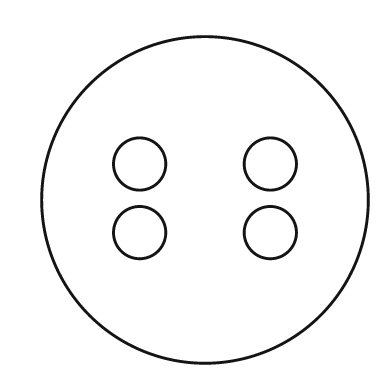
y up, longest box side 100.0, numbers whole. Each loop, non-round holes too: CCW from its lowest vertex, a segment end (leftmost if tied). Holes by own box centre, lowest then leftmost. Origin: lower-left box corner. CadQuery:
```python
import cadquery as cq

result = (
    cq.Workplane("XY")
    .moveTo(50.0, 50.0)
    .circle(50.0)
    .moveTo(30.0, 40.0)
    .circle(8.0)
    .moveTo(70.0, 40.0)
    .circle(8.0)
    .moveTo(30.0, 61.0)
    .circle(8.0)
    .moveTo(70.0, 61.0)
    .circle(8.0)
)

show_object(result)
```